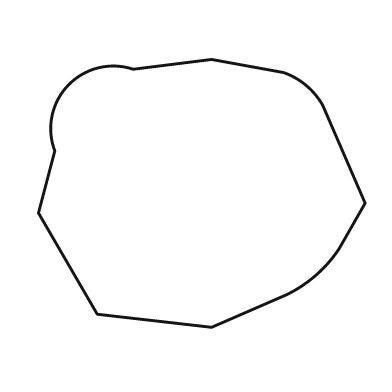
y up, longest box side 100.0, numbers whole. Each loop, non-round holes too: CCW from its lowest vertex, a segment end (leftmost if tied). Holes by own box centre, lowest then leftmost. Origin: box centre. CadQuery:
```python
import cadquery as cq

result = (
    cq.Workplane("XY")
    .moveTo(3.0, -41.0)
    .lineTo(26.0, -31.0)
    .threePointArc((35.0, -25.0), (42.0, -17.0))
    .lineTo(50.0, -3.0)
    .lineTo(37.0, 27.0)
    .threePointArc((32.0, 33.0), (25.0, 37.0))
    .lineTo(3.0, 41.0)
    .lineTo(-21.0, 38.0)
    .threePointArc((-41.0, 33.0), (-45.0, 13.0))
    .lineTo(-50.0, -6.0)
    .lineTo(-32.0, -37.0)
    .close()
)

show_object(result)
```